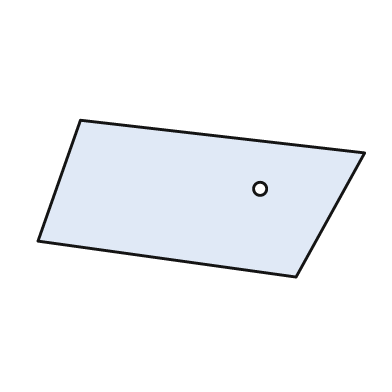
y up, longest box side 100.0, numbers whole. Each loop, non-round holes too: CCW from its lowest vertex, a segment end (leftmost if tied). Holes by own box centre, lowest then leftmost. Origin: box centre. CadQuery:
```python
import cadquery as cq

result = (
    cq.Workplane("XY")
    .moveTo(29.0, -24.0)
    .lineTo(50.0, 14.0)
    .lineTo(-37.0, 24.0)
    .lineTo(-50.0, -13.0)
    .close()
    .moveTo(18.0, 3.0)
    .circle(2.0)
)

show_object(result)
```